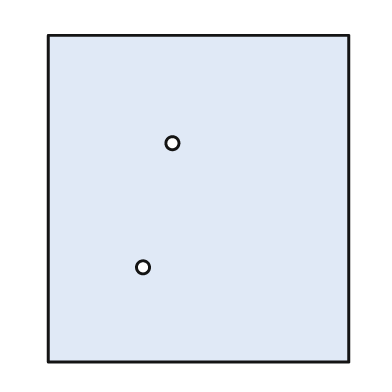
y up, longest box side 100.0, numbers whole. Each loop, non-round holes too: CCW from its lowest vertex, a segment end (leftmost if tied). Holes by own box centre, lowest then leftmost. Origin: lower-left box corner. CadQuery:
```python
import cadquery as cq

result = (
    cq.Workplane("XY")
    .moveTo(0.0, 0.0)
    .lineTo(92.0, 0.0)
    .lineTo(92.0, 100.0)
    .lineTo(0.0, 100.0)
    .close()
    .moveTo(29.0, 29.0)
    .circle(2.0)
    .moveTo(38.0, 67.0)
    .circle(2.0)
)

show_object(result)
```